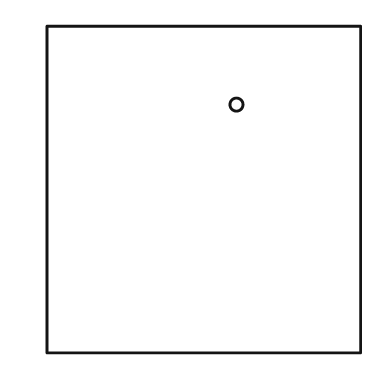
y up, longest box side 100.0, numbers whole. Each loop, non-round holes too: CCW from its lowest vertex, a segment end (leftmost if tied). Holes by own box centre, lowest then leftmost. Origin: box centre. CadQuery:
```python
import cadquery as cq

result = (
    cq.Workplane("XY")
    .moveTo(-48.0, -50.0)
    .lineTo(48.0, -50.0)
    .lineTo(48.0, 50.0)
    .lineTo(-48.0, 50.0)
    .close()
    .moveTo(10.0, 26.0)
    .circle(2.0)
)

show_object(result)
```